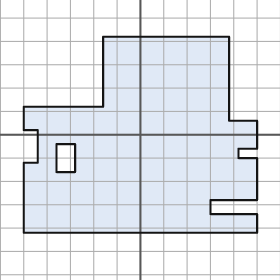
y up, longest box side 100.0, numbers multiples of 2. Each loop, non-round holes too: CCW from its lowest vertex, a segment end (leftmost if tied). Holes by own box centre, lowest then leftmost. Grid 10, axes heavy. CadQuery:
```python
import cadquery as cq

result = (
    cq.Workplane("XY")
    .moveTo(-50.0, -42.0)
    .lineTo(50.0, -42.0)
    .lineTo(50.0, -34.0)
    .lineTo(30.0, -34.0)
    .lineTo(30.0, -28.0)
    .lineTo(50.0, -28.0)
    .lineTo(50.0, -10.0)
    .lineTo(42.0, -10.0)
    .lineTo(42.0, -6.0)
    .lineTo(50.0, -6.0)
    .lineTo(50.0, 6.0)
    .lineTo(38.0, 6.0)
    .lineTo(38.0, 42.0)
    .lineTo(-16.0, 42.0)
    .lineTo(-16.0, 12.0)
    .lineTo(-50.0, 12.0)
    .lineTo(-50.0, 2.0)
    .lineTo(-44.0, 2.0)
    .lineTo(-44.0, -12.0)
    .lineTo(-50.0, -12.0)
    .close()
    .moveTo(-36.0, -16.0)
    .lineTo(-28.0, -16.0)
    .lineTo(-28.0, -4.0)
    .lineTo(-36.0, -4.0)
    .close()
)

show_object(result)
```